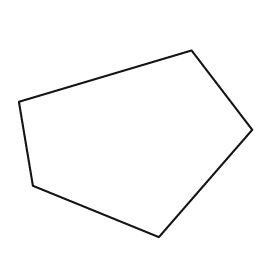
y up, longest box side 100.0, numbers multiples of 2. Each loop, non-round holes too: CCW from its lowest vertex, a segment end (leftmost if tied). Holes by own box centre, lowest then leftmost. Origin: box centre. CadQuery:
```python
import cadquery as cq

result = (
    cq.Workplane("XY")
    .moveTo(10.0, -40.0)
    .lineTo(50.0, 6.0)
    .lineTo(24.0, 40.0)
    .lineTo(-50.0, 18.0)
    .lineTo(-44.0, -18.0)
    .close()
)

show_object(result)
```